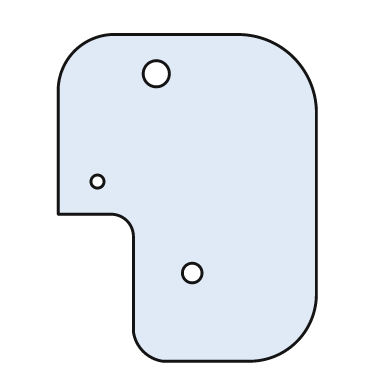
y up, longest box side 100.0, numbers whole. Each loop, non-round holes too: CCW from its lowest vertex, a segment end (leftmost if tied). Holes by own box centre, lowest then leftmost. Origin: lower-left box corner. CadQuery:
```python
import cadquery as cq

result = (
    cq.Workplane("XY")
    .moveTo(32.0, 0.0)
    .lineTo(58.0, 0.0)
    .threePointArc((73.0, 6.0), (79.0, 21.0))
    .lineTo(79.0, 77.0)
    .threePointArc((72.0, 93.0), (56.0, 100.0))
    .lineTo(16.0, 100.0)
    .threePointArc((5.0, 95.0), (0.0, 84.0))
    .lineTo(0.0, 45.0)
    .lineTo(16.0, 45.0)
    .threePointArc((21.0, 43.0), (23.0, 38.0))
    .lineTo(23.0, 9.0)
    .threePointArc((26.0, 3.0), (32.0, 0.0))
    .close()
    .moveTo(41.0, 27.0)
    .circle(3.0)
    .moveTo(12.0, 55.0)
    .circle(2.0)
    .moveTo(30.0, 88.0)
    .circle(4.0)
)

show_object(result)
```